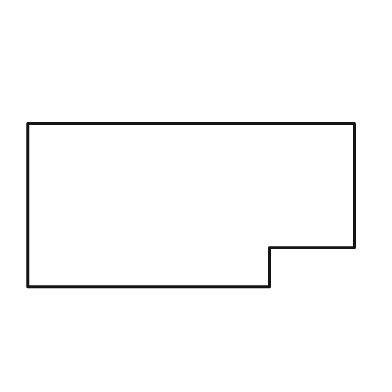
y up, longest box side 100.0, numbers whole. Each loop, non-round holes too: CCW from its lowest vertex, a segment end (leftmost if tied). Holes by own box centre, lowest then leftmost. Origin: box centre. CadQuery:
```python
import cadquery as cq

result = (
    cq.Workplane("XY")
    .moveTo(-50.0, -25.0)
    .lineTo(24.0, -25.0)
    .lineTo(24.0, -13.0)
    .lineTo(50.0, -13.0)
    .lineTo(50.0, 25.0)
    .lineTo(-50.0, 25.0)
    .close()
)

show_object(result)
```